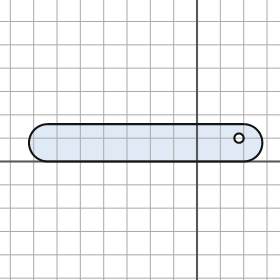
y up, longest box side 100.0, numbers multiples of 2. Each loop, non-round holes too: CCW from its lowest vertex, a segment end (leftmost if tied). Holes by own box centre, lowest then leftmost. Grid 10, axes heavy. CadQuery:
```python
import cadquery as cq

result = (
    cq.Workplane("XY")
    .moveTo(-64.0, 0.0)
    .lineTo(20.0, 0.0)
    .threePointArc((28.0, 8.0), (20.0, 16.0))
    .lineTo(-64.0, 16.0)
    .threePointArc((-72.0, 8.0), (-64.0, 0.0))
    .close()
    .moveTo(18.0, 10.0)
    .circle(2.0)
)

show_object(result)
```